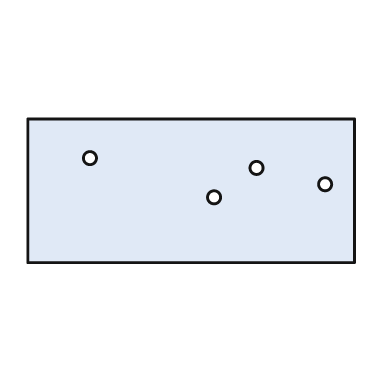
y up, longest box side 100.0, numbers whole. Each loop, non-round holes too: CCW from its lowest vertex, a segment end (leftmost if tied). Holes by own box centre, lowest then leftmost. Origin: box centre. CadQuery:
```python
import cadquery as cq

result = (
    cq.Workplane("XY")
    .moveTo(-50.0, -22.0)
    .lineTo(50.0, -22.0)
    .lineTo(50.0, 22.0)
    .lineTo(-50.0, 22.0)
    .close()
    .moveTo(7.0, -2.0)
    .circle(2.0)
    .moveTo(41.0, 2.0)
    .circle(2.0)
    .moveTo(20.0, 7.0)
    .circle(2.0)
    .moveTo(-31.0, 10.0)
    .circle(2.0)
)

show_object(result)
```